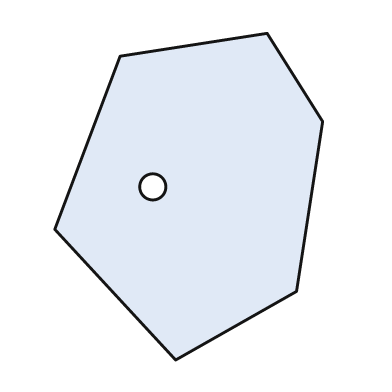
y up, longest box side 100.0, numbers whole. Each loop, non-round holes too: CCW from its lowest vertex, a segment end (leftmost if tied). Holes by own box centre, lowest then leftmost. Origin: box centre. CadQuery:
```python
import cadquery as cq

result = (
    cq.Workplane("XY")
    .moveTo(-4.0, -50.0)
    .lineTo(33.0, -29.0)
    .lineTo(41.0, 23.0)
    .lineTo(24.0, 50.0)
    .lineTo(-21.0, 43.0)
    .lineTo(-41.0, -10.0)
    .close()
    .moveTo(-11.0, 3.0)
    .circle(4.0)
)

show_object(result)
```